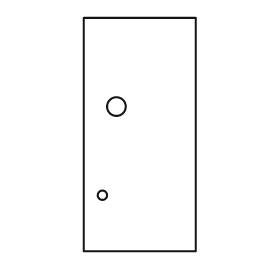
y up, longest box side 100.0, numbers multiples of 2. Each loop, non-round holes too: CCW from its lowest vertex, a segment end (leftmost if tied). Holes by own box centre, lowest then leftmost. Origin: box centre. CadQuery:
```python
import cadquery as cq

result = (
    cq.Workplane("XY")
    .moveTo(-24.0, -50.0)
    .lineTo(24.0, -50.0)
    .lineTo(24.0, 50.0)
    .lineTo(-24.0, 50.0)
    .close()
    .moveTo(-16.0, -26.0)
    .circle(2.0)
    .moveTo(-10.0, 12.0)
    .circle(4.0)
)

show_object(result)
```